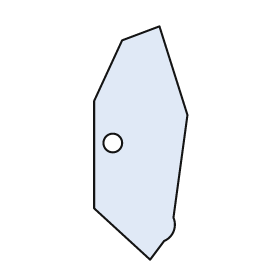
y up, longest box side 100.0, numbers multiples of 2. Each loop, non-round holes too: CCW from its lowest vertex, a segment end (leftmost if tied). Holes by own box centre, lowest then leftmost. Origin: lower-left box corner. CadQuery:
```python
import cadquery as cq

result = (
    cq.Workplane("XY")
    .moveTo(24.0, 0.0)
    .lineTo(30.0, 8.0)
    .threePointArc((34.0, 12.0), (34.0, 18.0))
    .lineTo(40.0, 62.0)
    .lineTo(28.0, 100.0)
    .lineTo(12.0, 94.0)
    .lineTo(0.0, 68.0)
    .lineTo(0.0, 22.0)
    .close()
    .moveTo(8.0, 50.0)
    .circle(4.0)
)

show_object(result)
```